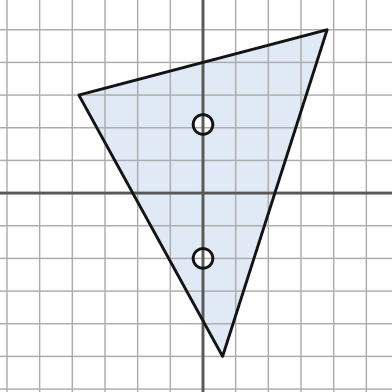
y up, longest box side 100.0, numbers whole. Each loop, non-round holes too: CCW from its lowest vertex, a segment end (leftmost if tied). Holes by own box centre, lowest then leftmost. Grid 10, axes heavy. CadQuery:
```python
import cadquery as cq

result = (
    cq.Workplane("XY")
    .moveTo(6.0, -50.0)
    .lineTo(38.0, 50.0)
    .lineTo(-38.0, 30.0)
    .close()
    .moveTo(0.0, -20.0)
    .circle(3.0)
    .moveTo(0.0, 21.0)
    .circle(3.0)
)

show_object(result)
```